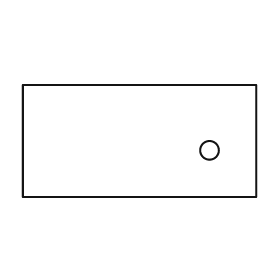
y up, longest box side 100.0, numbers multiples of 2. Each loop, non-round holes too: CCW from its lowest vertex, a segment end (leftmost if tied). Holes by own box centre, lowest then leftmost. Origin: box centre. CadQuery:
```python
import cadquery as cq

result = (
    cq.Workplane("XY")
    .moveTo(-50.0, -24.0)
    .lineTo(50.0, -24.0)
    .lineTo(50.0, 24.0)
    .lineTo(-50.0, 24.0)
    .close()
    .moveTo(30.0, -4.0)
    .circle(4.0)
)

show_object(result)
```